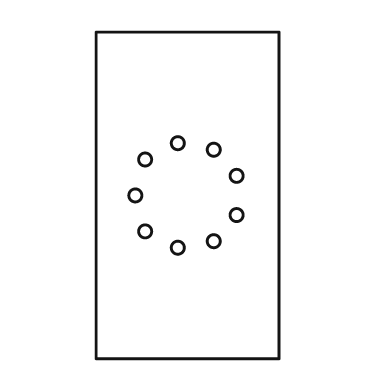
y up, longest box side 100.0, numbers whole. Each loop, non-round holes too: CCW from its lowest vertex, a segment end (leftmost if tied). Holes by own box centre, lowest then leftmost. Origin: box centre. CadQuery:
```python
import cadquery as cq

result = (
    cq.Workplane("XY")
    .moveTo(-28.0, -50.0)
    .lineTo(28.0, -50.0)
    .lineTo(28.0, 50.0)
    .lineTo(-28.0, 50.0)
    .close()
    .moveTo(-3.0, -16.0)
    .circle(2.0)
    .moveTo(8.0, -14.0)
    .circle(2.0)
    .moveTo(-13.0, -11.0)
    .circle(2.0)
    .moveTo(15.0, -6.0)
    .circle(2.0)
    .moveTo(-16.0, 0.0)
    .circle(2.0)
    .moveTo(15.0, 6.0)
    .circle(2.0)
    .moveTo(-13.0, 11.0)
    .circle(2.0)
    .moveTo(8.0, 14.0)
    .circle(2.0)
    .moveTo(-3.0, 16.0)
    .circle(2.0)
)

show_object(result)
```